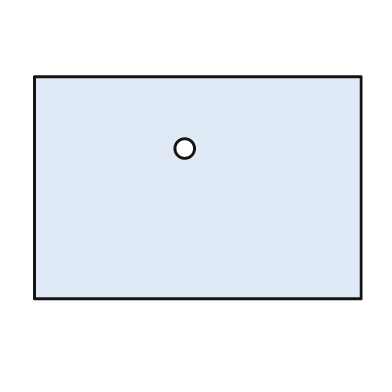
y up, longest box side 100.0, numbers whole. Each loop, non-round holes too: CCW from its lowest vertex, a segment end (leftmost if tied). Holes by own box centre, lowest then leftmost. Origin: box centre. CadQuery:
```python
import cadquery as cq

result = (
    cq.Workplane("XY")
    .moveTo(-50.0, -34.0)
    .lineTo(50.0, -34.0)
    .lineTo(50.0, 34.0)
    .lineTo(-50.0, 34.0)
    .close()
    .moveTo(-4.0, 12.0)
    .circle(3.0)
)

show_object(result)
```